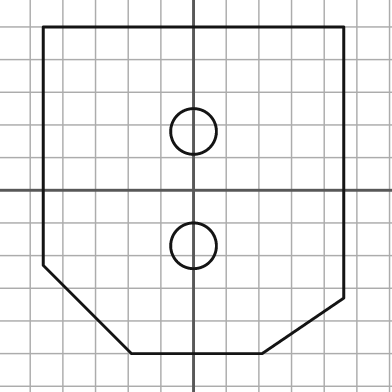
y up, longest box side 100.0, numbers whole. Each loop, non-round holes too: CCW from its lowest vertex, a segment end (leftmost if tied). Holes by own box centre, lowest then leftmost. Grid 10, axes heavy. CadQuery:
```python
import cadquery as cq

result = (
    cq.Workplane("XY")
    .moveTo(-19.0, -50.0)
    .lineTo(21.0, -50.0)
    .lineTo(46.0, -33.0)
    .lineTo(46.0, 50.0)
    .lineTo(-46.0, 50.0)
    .lineTo(-46.0, -23.0)
    .close()
    .moveTo(0.0, -17.0)
    .circle(7.0)
    .moveTo(0.0, 18.0)
    .circle(7.0)
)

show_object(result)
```